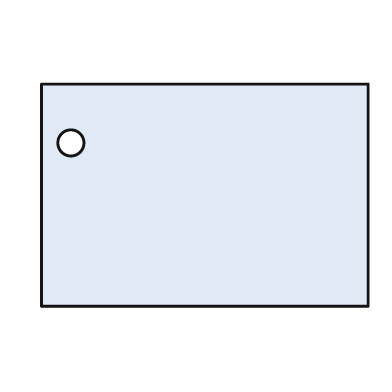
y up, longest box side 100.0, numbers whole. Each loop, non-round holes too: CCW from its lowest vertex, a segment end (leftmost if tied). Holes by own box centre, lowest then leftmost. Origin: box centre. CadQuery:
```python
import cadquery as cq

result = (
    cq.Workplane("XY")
    .moveTo(-50.0, -34.0)
    .lineTo(50.0, -34.0)
    .lineTo(50.0, 34.0)
    .lineTo(-50.0, 34.0)
    .close()
    .moveTo(-41.0, 16.0)
    .circle(4.0)
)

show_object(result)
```